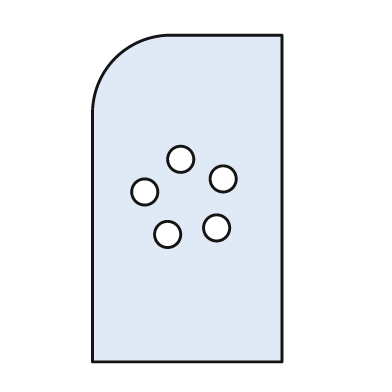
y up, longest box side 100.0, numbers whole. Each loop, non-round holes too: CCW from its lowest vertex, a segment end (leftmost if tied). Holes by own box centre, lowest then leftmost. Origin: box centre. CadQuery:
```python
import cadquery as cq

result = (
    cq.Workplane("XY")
    .moveTo(-29.0, -50.0)
    .lineTo(29.0, -50.0)
    .lineTo(29.0, 50.0)
    .lineTo(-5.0, 50.0)
    .threePointArc((-22.0, 43.0), (-29.0, 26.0))
    .close()
    .moveTo(-6.0, -11.0)
    .circle(4.0)
    .moveTo(9.0, -9.0)
    .circle(4.0)
    .moveTo(-13.0, 2.0)
    .circle(4.0)
    .moveTo(11.0, 6.0)
    .circle(4.0)
    .moveTo(-2.0, 12.0)
    .circle(4.0)
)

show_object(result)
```